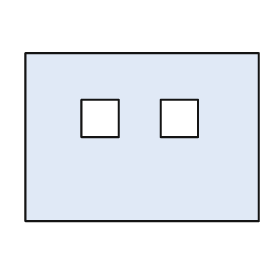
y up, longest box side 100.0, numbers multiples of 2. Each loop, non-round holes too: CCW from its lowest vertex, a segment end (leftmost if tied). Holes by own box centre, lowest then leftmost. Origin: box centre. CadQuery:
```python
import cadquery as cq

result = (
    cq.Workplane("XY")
    .moveTo(-50.0, -36.0)
    .lineTo(50.0, -36.0)
    .lineTo(50.0, 36.0)
    .lineTo(-50.0, 36.0)
    .close()
    .moveTo(-26.0, 0.0)
    .lineTo(-10.0, 0.0)
    .lineTo(-10.0, 16.0)
    .lineTo(-26.0, 16.0)
    .close()
    .moveTo(8.0, 0.0)
    .lineTo(24.0, 0.0)
    .lineTo(24.0, 16.0)
    .lineTo(8.0, 16.0)
    .close()
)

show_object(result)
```